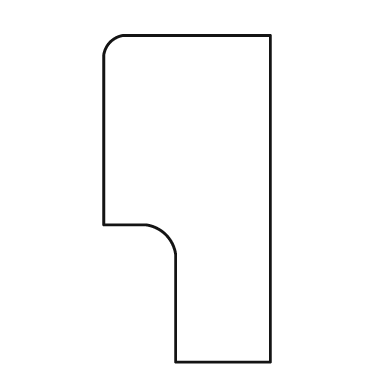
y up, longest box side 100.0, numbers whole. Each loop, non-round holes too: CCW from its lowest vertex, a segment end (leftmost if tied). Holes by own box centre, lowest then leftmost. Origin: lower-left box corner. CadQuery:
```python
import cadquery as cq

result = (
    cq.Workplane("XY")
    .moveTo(22.0, 0.0)
    .lineTo(51.0, 0.0)
    .lineTo(51.0, 100.0)
    .lineTo(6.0, 100.0)
    .threePointArc((2.0, 98.0), (0.0, 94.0))
    .lineTo(0.0, 42.0)
    .lineTo(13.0, 42.0)
    .threePointArc((19.0, 39.0), (22.0, 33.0))
    .close()
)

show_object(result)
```